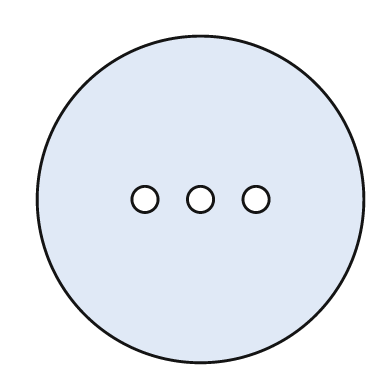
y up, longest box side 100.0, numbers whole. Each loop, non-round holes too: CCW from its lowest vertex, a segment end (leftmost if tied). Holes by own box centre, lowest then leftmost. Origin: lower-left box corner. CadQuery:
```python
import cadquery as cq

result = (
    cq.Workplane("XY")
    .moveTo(50.0, 50.0)
    .circle(50.0)
    .moveTo(33.0, 50.0)
    .circle(4.0)
    .moveTo(50.0, 50.0)
    .circle(4.0)
    .moveTo(67.0, 50.0)
    .circle(4.0)
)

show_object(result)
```